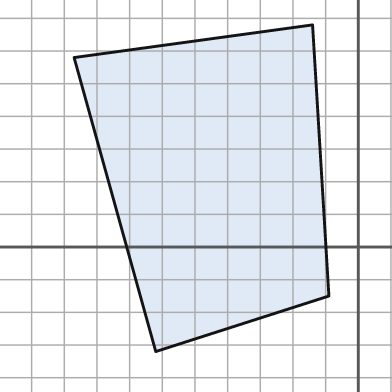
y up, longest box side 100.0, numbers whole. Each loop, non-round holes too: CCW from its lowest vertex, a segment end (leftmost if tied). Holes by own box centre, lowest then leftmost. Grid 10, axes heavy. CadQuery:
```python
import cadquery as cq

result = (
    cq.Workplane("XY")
    .moveTo(-62.0, -32.0)
    .lineTo(-9.0, -15.0)
    .lineTo(-14.0, 68.0)
    .lineTo(-87.0, 58.0)
    .close()
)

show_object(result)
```